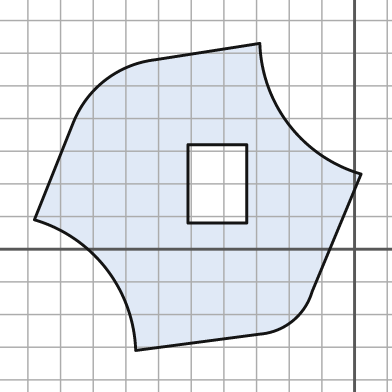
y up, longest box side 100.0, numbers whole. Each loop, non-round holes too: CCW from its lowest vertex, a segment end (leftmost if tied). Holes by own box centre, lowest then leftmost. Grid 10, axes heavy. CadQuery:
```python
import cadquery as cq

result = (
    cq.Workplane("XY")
    .moveTo(-67.0, -31.0)
    .lineTo(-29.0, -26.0)
    .threePointArc((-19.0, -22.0), (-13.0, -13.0))
    .lineTo(2.0, 23.0)
    .threePointArc((-20.0, 38.0), (-29.0, 63.0))
    .lineTo(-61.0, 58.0)
    .threePointArc((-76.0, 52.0), (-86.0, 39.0))
    .lineTo(-98.0, 9.0)
    .threePointArc((-76.0, -6.0), (-67.0, -31.0))
    .close()
    .moveTo(-51.0, 8.0)
    .lineTo(-33.0, 8.0)
    .lineTo(-33.0, 32.0)
    .lineTo(-51.0, 32.0)
    .close()
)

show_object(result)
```